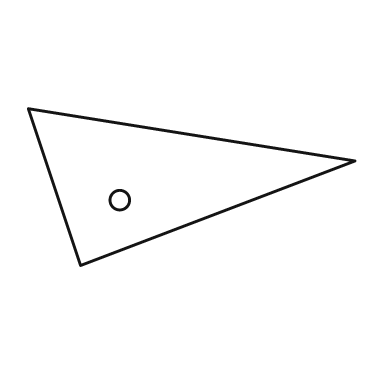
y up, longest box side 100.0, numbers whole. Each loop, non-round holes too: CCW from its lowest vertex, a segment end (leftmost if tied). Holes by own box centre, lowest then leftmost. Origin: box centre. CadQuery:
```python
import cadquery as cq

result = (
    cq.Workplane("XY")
    .moveTo(-34.0, -24.0)
    .lineTo(50.0, 8.0)
    .lineTo(-50.0, 24.0)
    .close()
    .moveTo(-22.0, -4.0)
    .circle(3.0)
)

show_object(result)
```